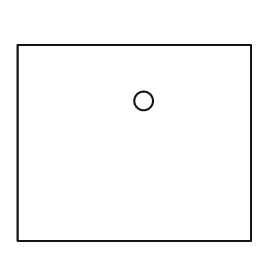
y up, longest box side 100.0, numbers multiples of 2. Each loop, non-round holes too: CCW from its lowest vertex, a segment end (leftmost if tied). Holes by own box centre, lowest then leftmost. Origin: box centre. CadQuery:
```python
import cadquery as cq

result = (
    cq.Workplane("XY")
    .moveTo(-50.0, -42.0)
    .lineTo(50.0, -42.0)
    .lineTo(50.0, 42.0)
    .lineTo(-50.0, 42.0)
    .close()
    .moveTo(4.0, 18.0)
    .circle(4.0)
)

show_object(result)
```